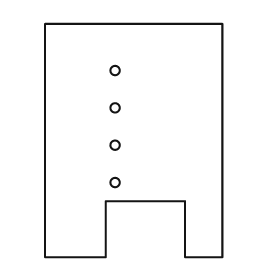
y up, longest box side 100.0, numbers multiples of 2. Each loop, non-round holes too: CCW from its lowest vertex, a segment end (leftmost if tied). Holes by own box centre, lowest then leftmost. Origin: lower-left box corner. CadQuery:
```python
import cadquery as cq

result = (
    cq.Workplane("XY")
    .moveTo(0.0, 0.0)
    .lineTo(26.0, 0.0)
    .lineTo(26.0, 24.0)
    .lineTo(60.0, 24.0)
    .lineTo(60.0, 0.0)
    .lineTo(76.0, 0.0)
    .lineTo(76.0, 100.0)
    .lineTo(0.0, 100.0)
    .close()
    .moveTo(30.0, 32.0)
    .circle(2.0)
    .moveTo(30.0, 48.0)
    .circle(2.0)
    .moveTo(30.0, 64.0)
    .circle(2.0)
    .moveTo(30.0, 80.0)
    .circle(2.0)
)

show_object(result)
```